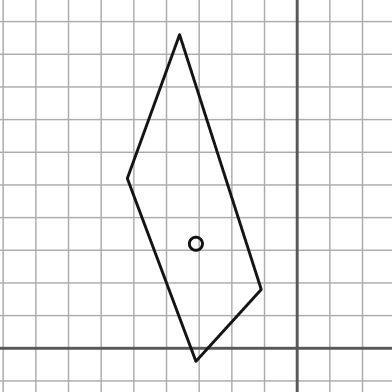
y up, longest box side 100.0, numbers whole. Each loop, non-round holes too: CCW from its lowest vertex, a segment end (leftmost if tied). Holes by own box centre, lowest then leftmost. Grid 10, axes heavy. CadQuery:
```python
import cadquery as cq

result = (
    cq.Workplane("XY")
    .moveTo(-31.0, -4.0)
    .lineTo(-11.0, 18.0)
    .lineTo(-36.0, 96.0)
    .lineTo(-52.0, 52.0)
    .close()
    .moveTo(-31.0, 32.0)
    .circle(2.0)
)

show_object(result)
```